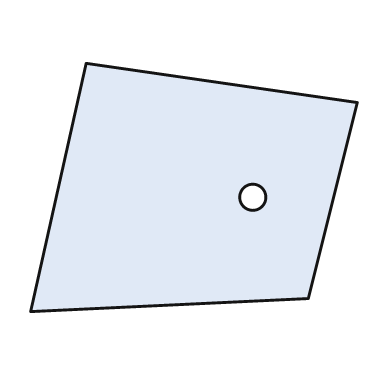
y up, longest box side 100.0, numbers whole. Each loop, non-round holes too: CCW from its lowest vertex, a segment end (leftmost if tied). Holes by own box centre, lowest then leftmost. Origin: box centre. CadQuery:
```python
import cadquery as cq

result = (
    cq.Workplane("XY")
    .moveTo(-50.0, -38.0)
    .lineTo(35.0, -34.0)
    .lineTo(50.0, 26.0)
    .lineTo(-33.0, 38.0)
    .close()
    .moveTo(18.0, -3.0)
    .circle(4.0)
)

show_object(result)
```